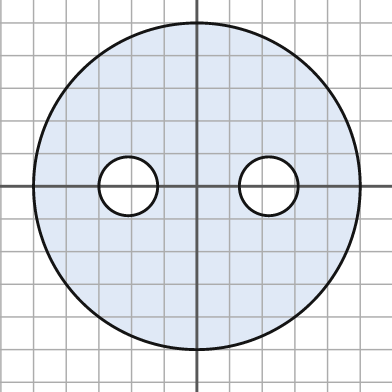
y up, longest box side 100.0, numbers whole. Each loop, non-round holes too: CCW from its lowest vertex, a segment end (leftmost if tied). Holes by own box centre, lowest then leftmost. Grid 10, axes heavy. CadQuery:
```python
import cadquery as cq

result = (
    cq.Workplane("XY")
    .moveTo(0.0, 0.0)
    .circle(50.0)
    .moveTo(-21.0, 0.0)
    .circle(9.0)
    .moveTo(22.0, 0.0)
    .circle(9.0)
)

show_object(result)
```